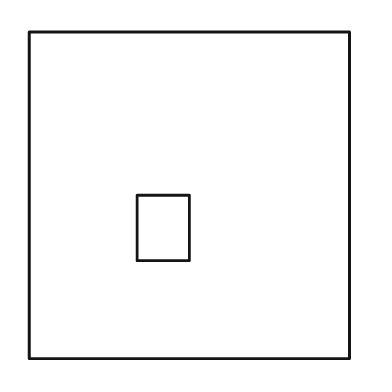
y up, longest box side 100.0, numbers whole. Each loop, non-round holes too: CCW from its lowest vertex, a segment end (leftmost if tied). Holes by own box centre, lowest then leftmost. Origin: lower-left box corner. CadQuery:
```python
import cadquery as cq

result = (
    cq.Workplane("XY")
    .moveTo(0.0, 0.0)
    .lineTo(98.0, 0.0)
    .lineTo(98.0, 100.0)
    .lineTo(0.0, 100.0)
    .close()
    .moveTo(33.0, 30.0)
    .lineTo(49.0, 30.0)
    .lineTo(49.0, 50.0)
    .lineTo(33.0, 50.0)
    .close()
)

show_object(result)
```